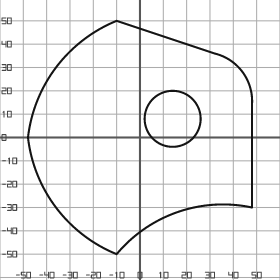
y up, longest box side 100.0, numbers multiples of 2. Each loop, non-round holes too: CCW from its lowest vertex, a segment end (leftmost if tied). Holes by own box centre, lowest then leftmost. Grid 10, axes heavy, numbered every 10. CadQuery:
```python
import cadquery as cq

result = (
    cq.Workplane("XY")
    .moveTo(-10.0, -50.0)
    .threePointArc((16.0, -32.0), (48.0, -30.0))
    .lineTo(48.0, 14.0)
    .threePointArc((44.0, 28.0), (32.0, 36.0))
    .lineTo(-10.0, 50.0)
    .threePointArc((-36.0, 30.0), (-48.0, 0.0))
    .threePointArc((-36.0, -30.0), (-10.0, -50.0))
    .close()
    .moveTo(14.0, 8.0)
    .circle(12.0)
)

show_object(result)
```